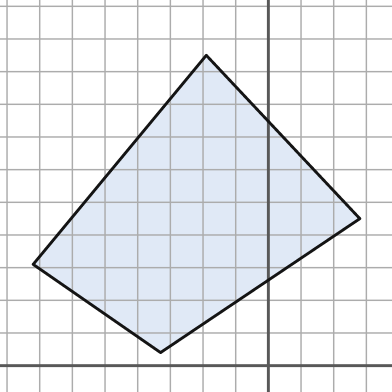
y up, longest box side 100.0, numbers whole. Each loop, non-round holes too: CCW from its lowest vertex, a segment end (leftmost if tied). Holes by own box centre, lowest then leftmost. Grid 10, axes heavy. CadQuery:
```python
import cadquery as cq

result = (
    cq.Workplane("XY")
    .moveTo(-33.0, 4.0)
    .lineTo(28.0, 45.0)
    .lineTo(-19.0, 95.0)
    .lineTo(-72.0, 31.0)
    .close()
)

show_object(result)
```